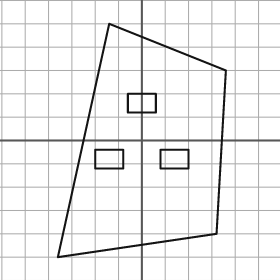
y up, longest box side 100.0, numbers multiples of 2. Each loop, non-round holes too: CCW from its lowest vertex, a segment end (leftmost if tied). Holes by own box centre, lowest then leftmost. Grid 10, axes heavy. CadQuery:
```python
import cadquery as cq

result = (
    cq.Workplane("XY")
    .moveTo(-36.0, -50.0)
    .lineTo(32.0, -40.0)
    .lineTo(36.0, 30.0)
    .lineTo(-14.0, 50.0)
    .close()
    .moveTo(-20.0, -12.0)
    .lineTo(-8.0, -12.0)
    .lineTo(-8.0, -4.0)
    .lineTo(-20.0, -4.0)
    .close()
    .moveTo(8.0, -12.0)
    .lineTo(20.0, -12.0)
    .lineTo(20.0, -4.0)
    .lineTo(8.0, -4.0)
    .close()
    .moveTo(-6.0, 12.0)
    .lineTo(6.0, 12.0)
    .lineTo(6.0, 20.0)
    .lineTo(-6.0, 20.0)
    .close()
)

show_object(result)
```